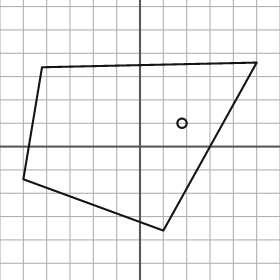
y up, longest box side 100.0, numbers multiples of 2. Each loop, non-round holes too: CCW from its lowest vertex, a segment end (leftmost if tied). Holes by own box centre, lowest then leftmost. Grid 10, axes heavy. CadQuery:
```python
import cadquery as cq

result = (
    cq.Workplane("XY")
    .moveTo(10.0, -36.0)
    .lineTo(50.0, 36.0)
    .lineTo(-42.0, 34.0)
    .lineTo(-50.0, -14.0)
    .close()
    .moveTo(18.0, 10.0)
    .circle(2.0)
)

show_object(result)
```